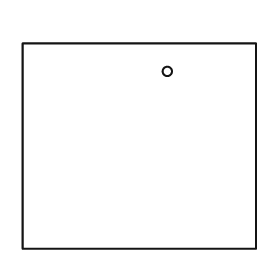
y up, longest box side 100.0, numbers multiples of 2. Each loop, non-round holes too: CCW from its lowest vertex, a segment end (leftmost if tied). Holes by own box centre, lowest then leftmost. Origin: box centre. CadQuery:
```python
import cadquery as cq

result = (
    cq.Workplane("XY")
    .moveTo(-50.0, -44.0)
    .lineTo(50.0, -44.0)
    .lineTo(50.0, 44.0)
    .lineTo(-50.0, 44.0)
    .close()
    .moveTo(12.0, 32.0)
    .circle(2.0)
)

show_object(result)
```